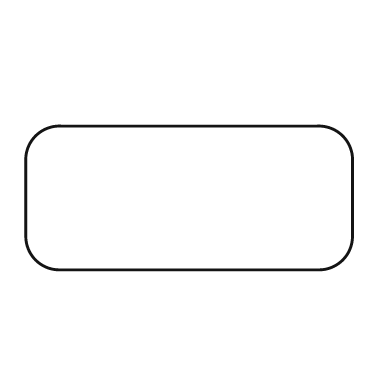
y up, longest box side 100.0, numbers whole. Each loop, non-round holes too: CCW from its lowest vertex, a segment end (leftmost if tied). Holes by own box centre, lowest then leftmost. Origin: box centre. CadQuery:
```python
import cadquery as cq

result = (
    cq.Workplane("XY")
    .moveTo(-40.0, -22.0)
    .lineTo(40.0, -22.0)
    .threePointArc((47.0, -19.0), (50.0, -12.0))
    .lineTo(50.0, 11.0)
    .threePointArc((47.0, 19.0), (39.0, 22.0))
    .lineTo(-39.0, 22.0)
    .threePointArc((-47.0, 19.0), (-50.0, 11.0))
    .lineTo(-50.0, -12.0)
    .threePointArc((-47.0, -19.0), (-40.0, -22.0))
    .close()
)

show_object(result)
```